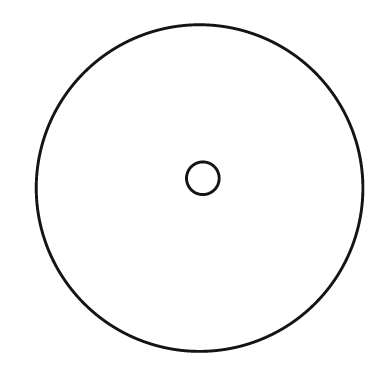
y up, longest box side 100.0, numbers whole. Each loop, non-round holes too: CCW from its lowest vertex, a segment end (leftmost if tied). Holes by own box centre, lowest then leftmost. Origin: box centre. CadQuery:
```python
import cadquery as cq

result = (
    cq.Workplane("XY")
    .moveTo(0.0, 0.0)
    .circle(50.0)
    .moveTo(1.0, 3.0)
    .circle(5.0)
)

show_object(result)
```